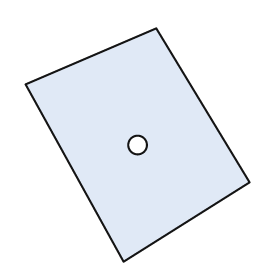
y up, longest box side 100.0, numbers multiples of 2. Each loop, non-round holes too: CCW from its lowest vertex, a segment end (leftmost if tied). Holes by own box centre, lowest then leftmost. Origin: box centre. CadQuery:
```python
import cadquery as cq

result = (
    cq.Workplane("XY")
    .moveTo(-6.0, -50.0)
    .lineTo(48.0, -16.0)
    .lineTo(8.0, 50.0)
    .lineTo(-48.0, 26.0)
    .close()
    .moveTo(0.0, 0.0)
    .circle(4.0)
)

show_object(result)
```